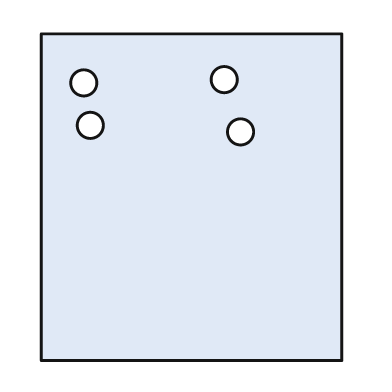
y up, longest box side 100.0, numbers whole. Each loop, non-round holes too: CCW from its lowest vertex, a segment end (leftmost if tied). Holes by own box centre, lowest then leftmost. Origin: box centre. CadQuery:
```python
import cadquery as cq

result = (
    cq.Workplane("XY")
    .moveTo(-46.0, -50.0)
    .lineTo(46.0, -50.0)
    .lineTo(46.0, 50.0)
    .lineTo(-46.0, 50.0)
    .close()
    .moveTo(15.0, 20.0)
    .circle(4.0)
    .moveTo(-31.0, 22.0)
    .circle(4.0)
    .moveTo(-33.0, 35.0)
    .circle(4.0)
    .moveTo(10.0, 36.0)
    .circle(4.0)
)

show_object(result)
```